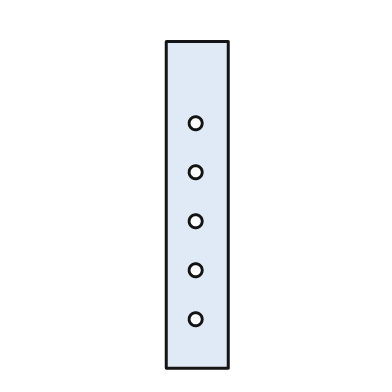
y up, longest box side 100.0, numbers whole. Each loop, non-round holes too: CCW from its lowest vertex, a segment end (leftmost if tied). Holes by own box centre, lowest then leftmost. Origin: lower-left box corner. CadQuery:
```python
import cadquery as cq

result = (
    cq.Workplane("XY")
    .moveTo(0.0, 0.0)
    .lineTo(19.0, 0.0)
    .lineTo(19.0, 100.0)
    .lineTo(0.0, 100.0)
    .close()
    .moveTo(9.0, 15.0)
    .circle(2.0)
    .moveTo(9.0, 30.0)
    .circle(2.0)
    .moveTo(9.0, 45.0)
    .circle(2.0)
    .moveTo(9.0, 60.0)
    .circle(2.0)
    .moveTo(9.0, 75.0)
    .circle(2.0)
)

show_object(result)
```